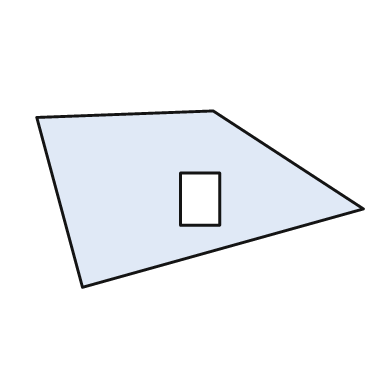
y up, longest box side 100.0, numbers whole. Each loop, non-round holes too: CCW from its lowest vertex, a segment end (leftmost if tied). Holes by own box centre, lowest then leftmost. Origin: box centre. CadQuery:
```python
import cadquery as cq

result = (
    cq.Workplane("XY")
    .moveTo(-36.0, -27.0)
    .lineTo(50.0, -3.0)
    .lineTo(4.0, 27.0)
    .lineTo(-50.0, 25.0)
    .close()
    .moveTo(-6.0, -8.0)
    .lineTo(6.0, -8.0)
    .lineTo(6.0, 8.0)
    .lineTo(-6.0, 8.0)
    .close()
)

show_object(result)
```